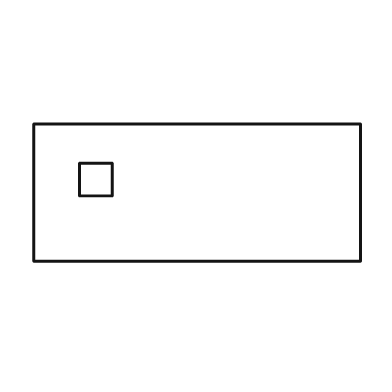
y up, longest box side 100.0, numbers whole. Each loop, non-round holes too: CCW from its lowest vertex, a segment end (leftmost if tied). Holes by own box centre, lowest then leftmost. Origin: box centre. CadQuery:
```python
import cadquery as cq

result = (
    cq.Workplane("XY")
    .moveTo(-50.0, -21.0)
    .lineTo(50.0, -21.0)
    .lineTo(50.0, 21.0)
    .lineTo(-50.0, 21.0)
    .close()
    .moveTo(-36.0, -1.0)
    .lineTo(-26.0, -1.0)
    .lineTo(-26.0, 9.0)
    .lineTo(-36.0, 9.0)
    .close()
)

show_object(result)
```